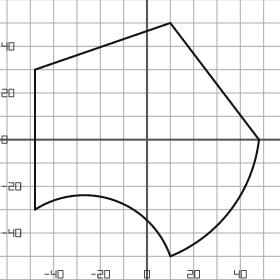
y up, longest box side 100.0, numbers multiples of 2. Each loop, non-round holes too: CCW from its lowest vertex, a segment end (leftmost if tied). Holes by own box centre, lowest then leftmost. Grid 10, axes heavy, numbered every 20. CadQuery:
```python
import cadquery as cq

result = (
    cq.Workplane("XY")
    .moveTo(10.0, -50.0)
    .threePointArc((36.0, -30.0), (48.0, 0.0))
    .lineTo(10.0, 50.0)
    .lineTo(-48.0, 30.0)
    .lineTo(-48.0, -30.0)
    .threePointArc((-14.0, -26.0), (10.0, -50.0))
    .close()
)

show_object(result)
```